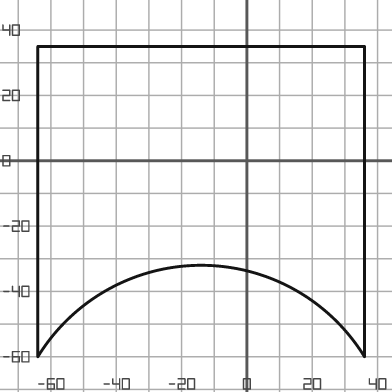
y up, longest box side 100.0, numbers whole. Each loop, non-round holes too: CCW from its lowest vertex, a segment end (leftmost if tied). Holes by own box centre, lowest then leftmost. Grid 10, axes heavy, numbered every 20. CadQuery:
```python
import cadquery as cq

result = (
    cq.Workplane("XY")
    .moveTo(-64.0, -60.0)
    .threePointArc((-14.0, -32.0), (36.0, -60.0))
    .lineTo(36.0, 35.0)
    .lineTo(-64.0, 35.0)
    .close()
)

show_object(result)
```